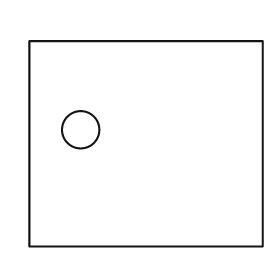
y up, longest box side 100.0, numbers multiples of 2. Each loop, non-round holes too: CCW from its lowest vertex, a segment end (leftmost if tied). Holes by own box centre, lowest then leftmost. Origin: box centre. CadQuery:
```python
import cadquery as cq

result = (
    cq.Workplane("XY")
    .moveTo(-50.0, -44.0)
    .lineTo(50.0, -44.0)
    .lineTo(50.0, 44.0)
    .lineTo(-50.0, 44.0)
    .close()
    .moveTo(-28.0, 6.0)
    .circle(8.0)
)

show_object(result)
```